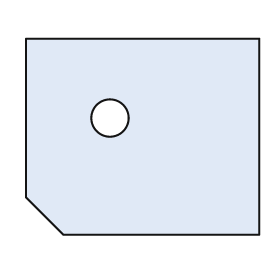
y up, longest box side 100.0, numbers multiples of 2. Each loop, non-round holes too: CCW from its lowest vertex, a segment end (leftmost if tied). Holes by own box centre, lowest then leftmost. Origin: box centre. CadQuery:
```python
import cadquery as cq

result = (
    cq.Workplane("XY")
    .moveTo(-34.0, -42.0)
    .lineTo(50.0, -42.0)
    .lineTo(50.0, 42.0)
    .lineTo(-50.0, 42.0)
    .lineTo(-50.0, -26.0)
    .close()
    .moveTo(-14.0, 8.0)
    .circle(8.0)
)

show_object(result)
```